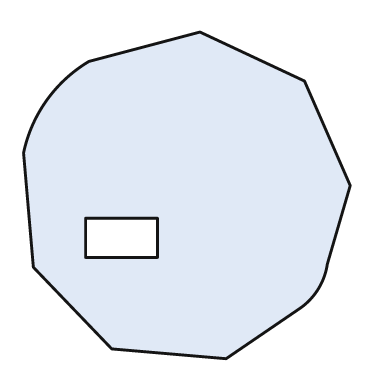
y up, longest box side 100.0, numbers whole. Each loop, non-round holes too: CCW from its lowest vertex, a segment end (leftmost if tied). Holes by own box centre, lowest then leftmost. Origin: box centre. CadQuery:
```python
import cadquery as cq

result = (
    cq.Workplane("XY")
    .moveTo(12.0, -50.0)
    .lineTo(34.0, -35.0)
    .threePointArc((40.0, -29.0), (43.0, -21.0))
    .lineTo(50.0, 3.0)
    .lineTo(36.0, 35.0)
    .lineTo(4.0, 50.0)
    .lineTo(-30.0, 41.0)
    .threePointArc((-43.0, 29.0), (-50.0, 13.0))
    .lineTo(-47.0, -22.0)
    .lineTo(-23.0, -47.0)
    .close()
    .moveTo(-31.0, -19.0)
    .lineTo(-9.0, -19.0)
    .lineTo(-9.0, -7.0)
    .lineTo(-31.0, -7.0)
    .close()
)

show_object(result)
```